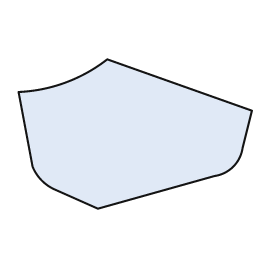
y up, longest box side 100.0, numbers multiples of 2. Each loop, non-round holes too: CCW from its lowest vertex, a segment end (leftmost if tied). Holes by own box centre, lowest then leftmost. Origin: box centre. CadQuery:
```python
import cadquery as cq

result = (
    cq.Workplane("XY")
    .moveTo(-16.0, -32.0)
    .lineTo(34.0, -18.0)
    .threePointArc((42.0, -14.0), (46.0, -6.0))
    .lineTo(50.0, 10.0)
    .lineTo(-12.0, 32.0)
    .threePointArc((-30.0, 22.0), (-50.0, 18.0))
    .lineTo(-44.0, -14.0)
    .threePointArc((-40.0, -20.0), (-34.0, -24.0))
    .close()
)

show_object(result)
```